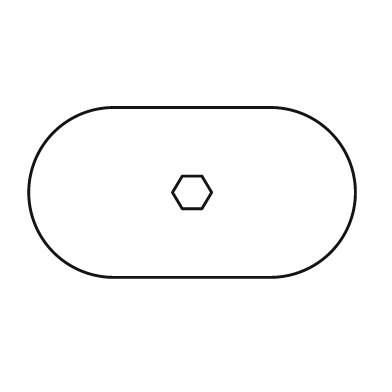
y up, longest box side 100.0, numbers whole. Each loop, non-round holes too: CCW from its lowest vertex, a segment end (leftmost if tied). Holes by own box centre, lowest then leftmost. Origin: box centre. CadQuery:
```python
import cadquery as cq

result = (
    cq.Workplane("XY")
    .moveTo(-24.0, -26.0)
    .lineTo(24.0, -26.0)
    .threePointArc((50.0, 0.0), (24.0, 26.0))
    .lineTo(-24.0, 26.0)
    .threePointArc((-50.0, 0.0), (-24.0, -26.0))
    .close()
    .moveTo(-3.0, -5.0)
    .lineTo(3.0, -5.0)
    .lineTo(6.0, 0.0)
    .lineTo(3.0, 5.0)
    .lineTo(-3.0, 5.0)
    .lineTo(-6.0, 0.0)
    .close()
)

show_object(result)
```